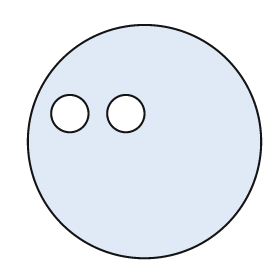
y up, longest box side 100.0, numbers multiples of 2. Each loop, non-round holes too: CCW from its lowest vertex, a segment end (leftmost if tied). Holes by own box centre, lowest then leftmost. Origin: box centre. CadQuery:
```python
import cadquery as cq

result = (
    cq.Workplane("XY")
    .moveTo(0.0, 0.0)
    .circle(50.0)
    .moveTo(-32.0, 12.0)
    .circle(8.0)
    .moveTo(-8.0, 12.0)
    .circle(8.0)
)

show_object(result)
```